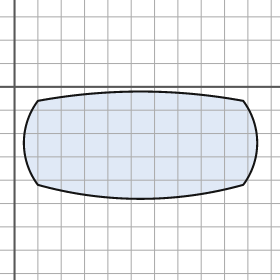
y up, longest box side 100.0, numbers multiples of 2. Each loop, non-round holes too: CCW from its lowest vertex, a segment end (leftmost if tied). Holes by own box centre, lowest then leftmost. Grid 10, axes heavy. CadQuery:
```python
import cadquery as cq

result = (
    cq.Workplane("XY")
    .moveTo(10.0, -42.0)
    .threePointArc((54.0, -48.0), (98.0, -42.0))
    .threePointArc((104.0, -24.0), (98.0, -6.0))
    .threePointArc((54.0, -2.0), (10.0, -6.0))
    .threePointArc((4.0, -24.0), (10.0, -42.0))
    .close()
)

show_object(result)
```